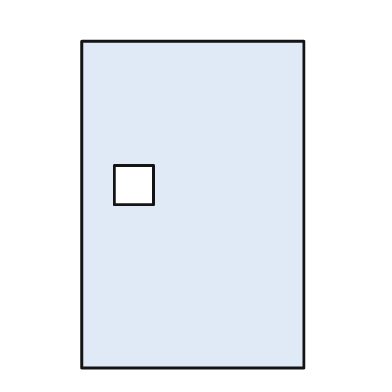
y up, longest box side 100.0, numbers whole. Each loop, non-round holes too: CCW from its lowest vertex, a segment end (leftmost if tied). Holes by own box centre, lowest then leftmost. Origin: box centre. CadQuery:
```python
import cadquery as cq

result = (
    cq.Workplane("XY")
    .moveTo(-34.0, -50.0)
    .lineTo(34.0, -50.0)
    .lineTo(34.0, 50.0)
    .lineTo(-34.0, 50.0)
    .close()
    .moveTo(-24.0, 0.0)
    .lineTo(-12.0, 0.0)
    .lineTo(-12.0, 12.0)
    .lineTo(-24.0, 12.0)
    .close()
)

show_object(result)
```